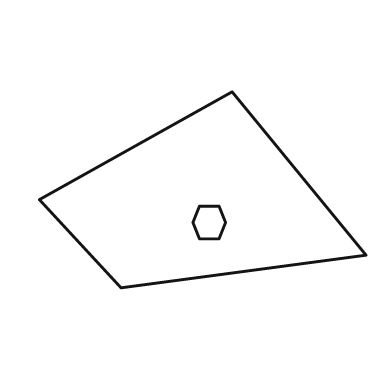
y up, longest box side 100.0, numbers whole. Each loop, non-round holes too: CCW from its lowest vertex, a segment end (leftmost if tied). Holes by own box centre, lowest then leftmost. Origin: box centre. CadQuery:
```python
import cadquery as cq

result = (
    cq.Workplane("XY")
    .moveTo(-25.0, -30.0)
    .lineTo(50.0, -20.0)
    .lineTo(9.0, 30.0)
    .lineTo(-50.0, -3.0)
    .close()
    .moveTo(-1.0, -15.0)
    .lineTo(5.0, -15.0)
    .lineTo(7.0, -10.0)
    .lineTo(5.0, -5.0)
    .lineTo(-1.0, -5.0)
    .lineTo(-3.0, -10.0)
    .close()
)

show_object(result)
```